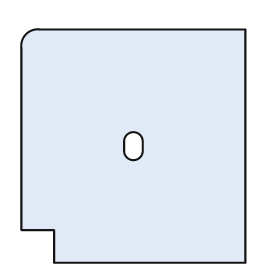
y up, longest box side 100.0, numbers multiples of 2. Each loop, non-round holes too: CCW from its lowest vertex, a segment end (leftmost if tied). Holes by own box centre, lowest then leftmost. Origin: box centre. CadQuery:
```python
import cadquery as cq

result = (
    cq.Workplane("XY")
    .moveTo(-34.0, -50.0)
    .lineTo(48.0, -50.0)
    .lineTo(48.0, 50.0)
    .lineTo(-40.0, 50.0)
    .threePointArc((-46.0, 48.0), (-48.0, 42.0))
    .lineTo(-48.0, -36.0)
    .lineTo(-34.0, -36.0)
    .close()
    .moveTo(-4.0, -2.0)
    .threePointArc((0.0, -6.0), (4.0, -2.0))
    .lineTo(4.0, 2.0)
    .threePointArc((0.0, 6.0), (-4.0, 2.0))
    .close()
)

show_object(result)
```